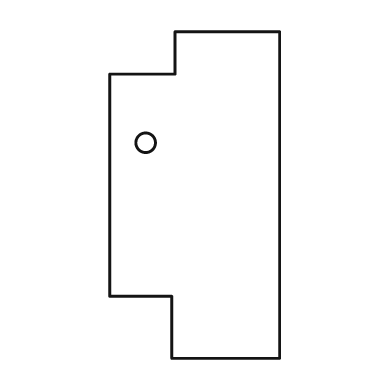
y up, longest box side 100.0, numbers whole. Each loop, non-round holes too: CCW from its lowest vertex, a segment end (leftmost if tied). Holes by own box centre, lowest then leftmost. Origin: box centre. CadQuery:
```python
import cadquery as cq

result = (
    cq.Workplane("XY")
    .moveTo(-7.0, -50.0)
    .lineTo(26.0, -50.0)
    .lineTo(26.0, 50.0)
    .lineTo(-6.0, 50.0)
    .lineTo(-6.0, 37.0)
    .lineTo(-26.0, 37.0)
    .lineTo(-26.0, -31.0)
    .lineTo(-7.0, -31.0)
    .close()
    .moveTo(-15.0, 16.0)
    .circle(3.0)
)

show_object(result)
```